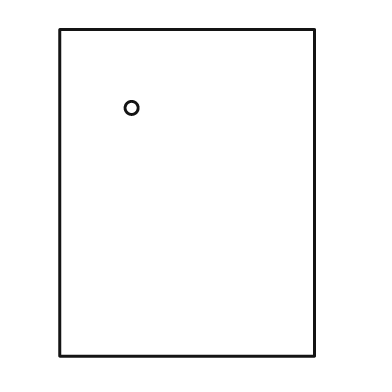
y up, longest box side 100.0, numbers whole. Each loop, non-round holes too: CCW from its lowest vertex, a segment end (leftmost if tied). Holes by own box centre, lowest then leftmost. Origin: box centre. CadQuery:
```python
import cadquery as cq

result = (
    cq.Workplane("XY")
    .moveTo(-39.0, -50.0)
    .lineTo(39.0, -50.0)
    .lineTo(39.0, 50.0)
    .lineTo(-39.0, 50.0)
    .close()
    .moveTo(-17.0, 26.0)
    .circle(2.0)
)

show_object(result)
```